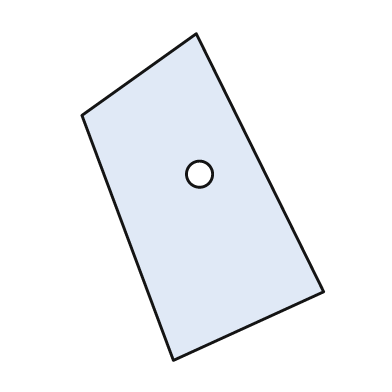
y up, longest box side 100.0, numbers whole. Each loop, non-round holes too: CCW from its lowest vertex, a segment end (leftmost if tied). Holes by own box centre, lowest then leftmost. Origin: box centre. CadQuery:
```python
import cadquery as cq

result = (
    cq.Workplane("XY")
    .moveTo(-9.0, -50.0)
    .lineTo(37.0, -29.0)
    .lineTo(-2.0, 50.0)
    .lineTo(-37.0, 25.0)
    .close()
    .moveTo(-1.0, 7.0)
    .circle(4.0)
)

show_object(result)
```